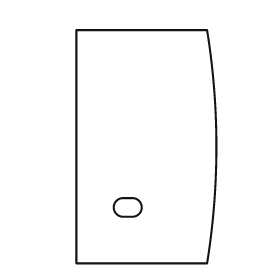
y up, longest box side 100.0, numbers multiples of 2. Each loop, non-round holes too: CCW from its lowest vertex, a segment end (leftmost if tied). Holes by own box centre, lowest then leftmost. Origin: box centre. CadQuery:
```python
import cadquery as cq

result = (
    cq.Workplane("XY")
    .moveTo(-30.0, -50.0)
    .lineTo(26.0, -50.0)
    .threePointArc((30.0, 0.0), (26.0, 50.0))
    .lineTo(-30.0, 50.0)
    .close()
    .moveTo(-10.0, -30.0)
    .lineTo(-6.0, -30.0)
    .threePointArc((-2.0, -26.0), (-6.0, -22.0))
    .lineTo(-10.0, -22.0)
    .threePointArc((-14.0, -26.0), (-10.0, -30.0))
    .close()
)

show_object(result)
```